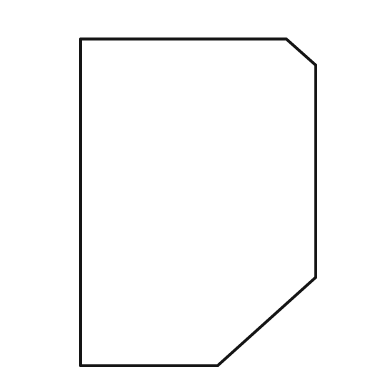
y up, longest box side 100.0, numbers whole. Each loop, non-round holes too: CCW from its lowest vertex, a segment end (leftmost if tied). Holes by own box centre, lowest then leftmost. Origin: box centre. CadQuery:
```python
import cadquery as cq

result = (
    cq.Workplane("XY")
    .moveTo(-36.0, -50.0)
    .lineTo(6.0, -50.0)
    .lineTo(36.0, -23.0)
    .lineTo(36.0, 42.0)
    .lineTo(27.0, 50.0)
    .lineTo(-36.0, 50.0)
    .close()
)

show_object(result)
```